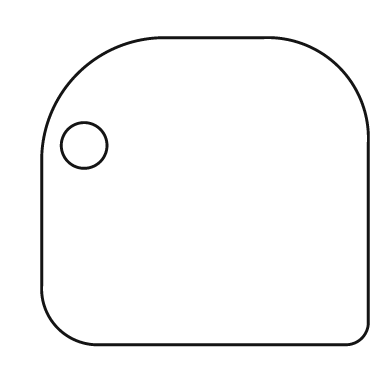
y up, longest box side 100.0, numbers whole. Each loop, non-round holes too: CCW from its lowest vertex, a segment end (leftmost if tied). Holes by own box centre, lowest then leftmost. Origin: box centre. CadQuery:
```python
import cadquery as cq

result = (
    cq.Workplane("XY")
    .moveTo(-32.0, -47.0)
    .lineTo(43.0, -47.0)
    .threePointArc((48.0, -45.0), (50.0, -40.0))
    .lineTo(50.0, 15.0)
    .threePointArc((41.0, 38.0), (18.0, 47.0))
    .lineTo(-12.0, 47.0)
    .threePointArc((-39.0, 36.0), (-50.0, 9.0))
    .lineTo(-50.0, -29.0)
    .threePointArc((-45.0, -42.0), (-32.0, -47.0))
    .close()
    .moveTo(-37.0, 14.0)
    .circle(7.0)
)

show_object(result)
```